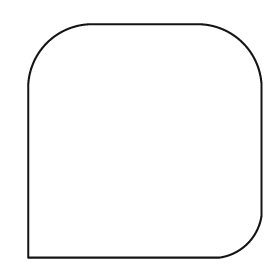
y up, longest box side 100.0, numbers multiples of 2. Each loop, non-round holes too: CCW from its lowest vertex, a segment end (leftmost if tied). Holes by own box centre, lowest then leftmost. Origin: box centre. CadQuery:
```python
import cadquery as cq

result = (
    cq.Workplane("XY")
    .moveTo(-50.0, -50.0)
    .lineTo(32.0, -50.0)
    .threePointArc((44.0, -44.0), (50.0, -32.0))
    .lineTo(50.0, 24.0)
    .threePointArc((42.0, 42.0), (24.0, 50.0))
    .lineTo(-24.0, 50.0)
    .threePointArc((-42.0, 42.0), (-50.0, 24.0))
    .close()
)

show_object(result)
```